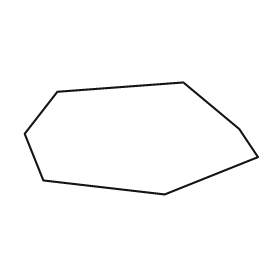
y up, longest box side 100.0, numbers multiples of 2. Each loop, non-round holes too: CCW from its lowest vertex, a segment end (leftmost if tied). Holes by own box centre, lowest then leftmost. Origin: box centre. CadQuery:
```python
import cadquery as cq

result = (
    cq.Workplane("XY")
    .moveTo(10.0, -24.0)
    .lineTo(50.0, -8.0)
    .lineTo(42.0, 4.0)
    .lineTo(18.0, 24.0)
    .lineTo(-36.0, 20.0)
    .lineTo(-50.0, 2.0)
    .lineTo(-42.0, -18.0)
    .close()
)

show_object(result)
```